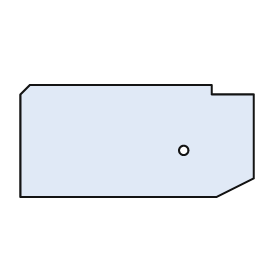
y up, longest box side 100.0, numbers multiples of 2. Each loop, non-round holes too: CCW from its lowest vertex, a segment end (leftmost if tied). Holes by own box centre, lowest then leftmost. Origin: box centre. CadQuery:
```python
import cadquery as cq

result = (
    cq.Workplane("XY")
    .moveTo(-50.0, -24.0)
    .lineTo(34.0, -24.0)
    .lineTo(50.0, -16.0)
    .lineTo(50.0, 20.0)
    .lineTo(32.0, 20.0)
    .lineTo(32.0, 24.0)
    .lineTo(-46.0, 24.0)
    .lineTo(-50.0, 20.0)
    .close()
    .moveTo(20.0, -4.0)
    .circle(2.0)
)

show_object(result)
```